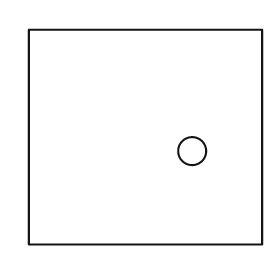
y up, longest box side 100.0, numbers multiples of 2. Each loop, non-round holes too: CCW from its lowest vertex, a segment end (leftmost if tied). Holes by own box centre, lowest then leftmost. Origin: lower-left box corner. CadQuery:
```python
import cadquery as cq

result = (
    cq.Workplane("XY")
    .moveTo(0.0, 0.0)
    .lineTo(100.0, 0.0)
    .lineTo(100.0, 92.0)
    .lineTo(0.0, 92.0)
    .close()
    .moveTo(70.0, 40.0)
    .circle(6.0)
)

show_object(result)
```